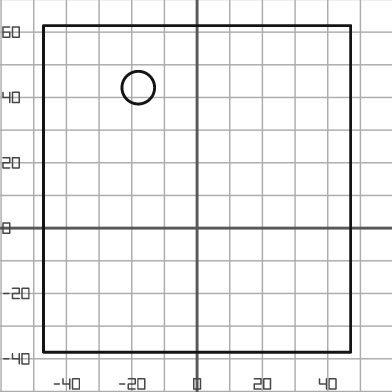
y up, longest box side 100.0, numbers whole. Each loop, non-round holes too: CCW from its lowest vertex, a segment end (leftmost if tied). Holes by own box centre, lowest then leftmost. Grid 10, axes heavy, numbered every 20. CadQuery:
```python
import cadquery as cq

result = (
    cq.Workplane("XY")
    .moveTo(-47.0, -38.0)
    .lineTo(47.0, -38.0)
    .lineTo(47.0, 62.0)
    .lineTo(-47.0, 62.0)
    .close()
    .moveTo(-18.0, 43.0)
    .circle(5.0)
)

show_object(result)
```